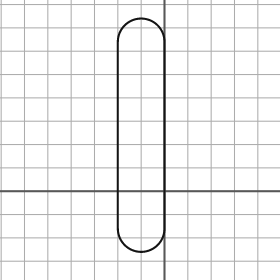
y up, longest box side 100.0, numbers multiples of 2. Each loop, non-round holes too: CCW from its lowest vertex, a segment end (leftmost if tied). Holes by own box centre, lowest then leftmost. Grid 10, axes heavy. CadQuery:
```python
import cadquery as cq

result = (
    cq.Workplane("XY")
    .moveTo(-20.0, -16.0)
    .threePointArc((-10.0, -26.0), (0.0, -16.0))
    .lineTo(0.0, 64.0)
    .threePointArc((-10.0, 74.0), (-20.0, 64.0))
    .close()
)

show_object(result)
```